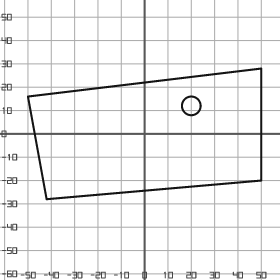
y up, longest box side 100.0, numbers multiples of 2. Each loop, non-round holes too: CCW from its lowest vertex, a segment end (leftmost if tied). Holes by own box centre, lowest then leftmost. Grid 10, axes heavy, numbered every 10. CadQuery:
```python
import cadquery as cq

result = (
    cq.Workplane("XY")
    .moveTo(-42.0, -28.0)
    .lineTo(50.0, -20.0)
    .lineTo(50.0, 28.0)
    .lineTo(-50.0, 16.0)
    .close()
    .moveTo(20.0, 12.0)
    .circle(4.0)
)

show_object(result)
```